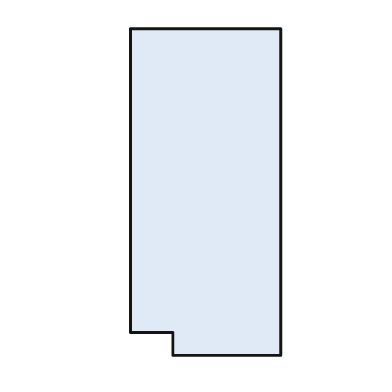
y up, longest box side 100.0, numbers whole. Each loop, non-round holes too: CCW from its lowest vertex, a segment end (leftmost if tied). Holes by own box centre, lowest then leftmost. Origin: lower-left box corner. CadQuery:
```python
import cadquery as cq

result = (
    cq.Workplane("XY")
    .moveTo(13.0, 0.0)
    .lineTo(46.0, 0.0)
    .lineTo(46.0, 100.0)
    .lineTo(0.0, 100.0)
    .lineTo(0.0, 7.0)
    .lineTo(13.0, 7.0)
    .close()
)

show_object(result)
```